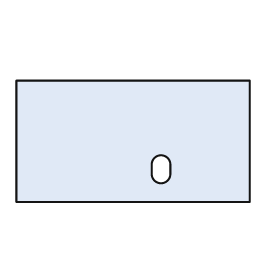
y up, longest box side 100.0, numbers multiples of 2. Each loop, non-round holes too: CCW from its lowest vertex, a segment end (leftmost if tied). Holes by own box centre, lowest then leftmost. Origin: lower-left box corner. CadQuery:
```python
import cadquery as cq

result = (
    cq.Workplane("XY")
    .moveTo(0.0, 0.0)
    .lineTo(100.0, 0.0)
    .lineTo(100.0, 52.0)
    .lineTo(0.0, 52.0)
    .close()
    .moveTo(58.0, 12.0)
    .threePointArc((62.0, 8.0), (66.0, 12.0))
    .lineTo(66.0, 16.0)
    .threePointArc((62.0, 20.0), (58.0, 16.0))
    .close()
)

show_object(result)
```